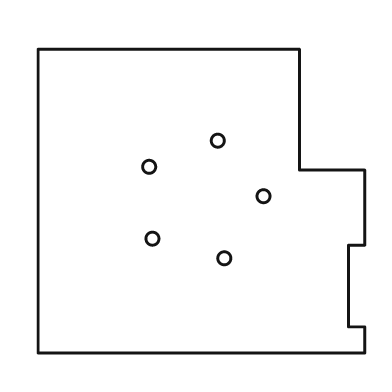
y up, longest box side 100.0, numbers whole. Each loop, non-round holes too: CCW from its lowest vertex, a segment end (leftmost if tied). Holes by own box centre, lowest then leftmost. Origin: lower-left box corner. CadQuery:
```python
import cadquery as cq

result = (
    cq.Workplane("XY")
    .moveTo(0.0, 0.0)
    .lineTo(100.0, 0.0)
    .lineTo(100.0, 8.0)
    .lineTo(95.0, 8.0)
    .lineTo(95.0, 33.0)
    .lineTo(100.0, 33.0)
    .lineTo(100.0, 56.0)
    .lineTo(80.0, 56.0)
    .lineTo(80.0, 93.0)
    .lineTo(0.0, 93.0)
    .close()
    .moveTo(57.0, 29.0)
    .circle(2.0)
    .moveTo(35.0, 35.0)
    .circle(2.0)
    .moveTo(69.0, 48.0)
    .circle(2.0)
    .moveTo(34.0, 57.0)
    .circle(2.0)
    .moveTo(55.0, 65.0)
    .circle(2.0)
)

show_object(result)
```